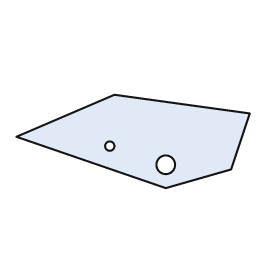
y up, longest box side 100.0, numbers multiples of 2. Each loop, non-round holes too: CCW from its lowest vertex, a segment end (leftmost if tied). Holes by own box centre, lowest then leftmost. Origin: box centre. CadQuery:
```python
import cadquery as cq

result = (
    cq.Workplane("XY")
    .moveTo(14.0, -20.0)
    .lineTo(42.0, -12.0)
    .lineTo(50.0, 12.0)
    .lineTo(-8.0, 20.0)
    .lineTo(-50.0, 2.0)
    .close()
    .moveTo(14.0, -10.0)
    .circle(4.0)
    .moveTo(-10.0, -2.0)
    .circle(2.0)
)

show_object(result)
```